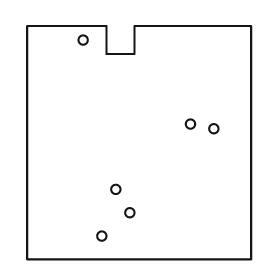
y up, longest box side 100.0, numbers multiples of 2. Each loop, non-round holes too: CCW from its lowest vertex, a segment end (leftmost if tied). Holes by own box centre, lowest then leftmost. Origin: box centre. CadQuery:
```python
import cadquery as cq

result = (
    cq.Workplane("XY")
    .moveTo(-48.0, -50.0)
    .lineTo(48.0, -50.0)
    .lineTo(48.0, 50.0)
    .lineTo(-2.0, 50.0)
    .lineTo(-2.0, 38.0)
    .lineTo(-14.0, 38.0)
    .lineTo(-14.0, 50.0)
    .lineTo(-48.0, 50.0)
    .close()
    .moveTo(-16.0, -40.0)
    .circle(2.0)
    .moveTo(-4.0, -30.0)
    .circle(2.0)
    .moveTo(-10.0, -20.0)
    .circle(2.0)
    .moveTo(32.0, 6.0)
    .circle(2.0)
    .moveTo(22.0, 8.0)
    .circle(2.0)
    .moveTo(-24.0, 44.0)
    .circle(2.0)
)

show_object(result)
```